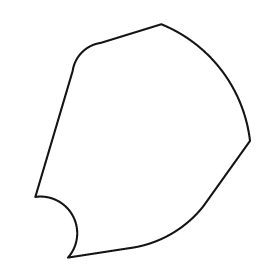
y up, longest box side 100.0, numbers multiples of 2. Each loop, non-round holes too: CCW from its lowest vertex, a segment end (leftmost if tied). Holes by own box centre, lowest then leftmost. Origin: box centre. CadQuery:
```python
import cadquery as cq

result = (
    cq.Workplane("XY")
    .moveTo(-32.0, -50.0)
    .lineTo(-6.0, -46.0)
    .threePointArc((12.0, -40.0), (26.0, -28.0))
    .lineTo(46.0, 0.0)
    .threePointArc((34.0, 30.0), (8.0, 50.0))
    .lineTo(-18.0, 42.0)
    .threePointArc((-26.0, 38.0), (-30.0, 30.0))
    .lineTo(-46.0, -24.0)
    .threePointArc((-30.0, -32.0), (-32.0, -50.0))
    .close()
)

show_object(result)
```